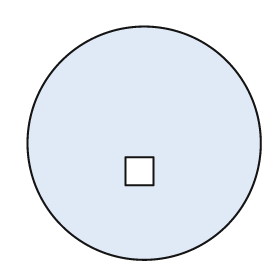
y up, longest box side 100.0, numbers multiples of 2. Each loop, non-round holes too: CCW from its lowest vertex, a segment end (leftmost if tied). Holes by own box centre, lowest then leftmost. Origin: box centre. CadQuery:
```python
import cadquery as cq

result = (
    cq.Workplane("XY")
    .moveTo(0.0, 0.0)
    .circle(50.0)
    .moveTo(-8.0, -18.0)
    .lineTo(4.0, -18.0)
    .lineTo(4.0, -6.0)
    .lineTo(-8.0, -6.0)
    .close()
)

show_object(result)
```